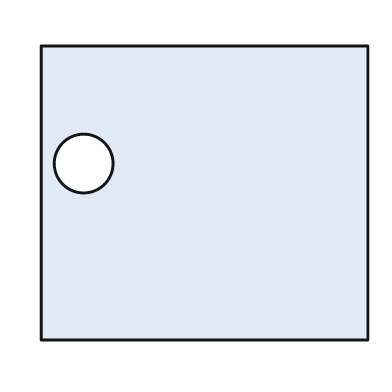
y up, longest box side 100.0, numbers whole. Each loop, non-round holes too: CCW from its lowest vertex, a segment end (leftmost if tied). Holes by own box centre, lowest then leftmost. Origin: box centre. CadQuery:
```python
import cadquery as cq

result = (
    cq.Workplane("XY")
    .moveTo(-50.0, -45.0)
    .lineTo(50.0, -45.0)
    .lineTo(50.0, 45.0)
    .lineTo(-50.0, 45.0)
    .close()
    .moveTo(-37.0, 9.0)
    .circle(9.0)
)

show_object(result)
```